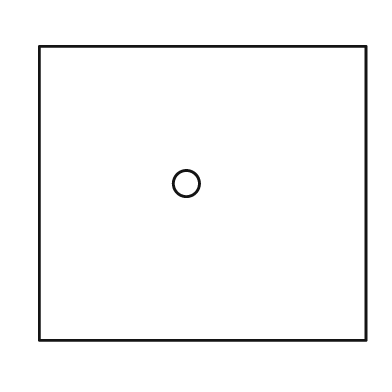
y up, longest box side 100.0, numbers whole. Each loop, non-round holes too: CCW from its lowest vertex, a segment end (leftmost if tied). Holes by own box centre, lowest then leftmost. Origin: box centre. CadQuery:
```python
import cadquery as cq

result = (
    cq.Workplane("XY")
    .moveTo(-50.0, -45.0)
    .lineTo(50.0, -45.0)
    .lineTo(50.0, 45.0)
    .lineTo(-50.0, 45.0)
    .close()
    .moveTo(-5.0, 3.0)
    .circle(4.0)
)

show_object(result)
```